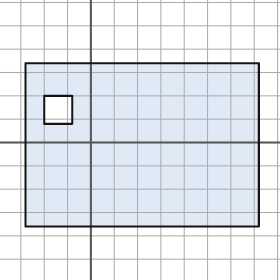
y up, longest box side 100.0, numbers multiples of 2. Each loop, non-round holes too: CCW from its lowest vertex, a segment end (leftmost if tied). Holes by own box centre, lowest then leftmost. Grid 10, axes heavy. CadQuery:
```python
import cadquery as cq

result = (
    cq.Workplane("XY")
    .moveTo(-28.0, -36.0)
    .lineTo(72.0, -36.0)
    .lineTo(72.0, 34.0)
    .lineTo(-28.0, 34.0)
    .close()
    .moveTo(-20.0, 8.0)
    .lineTo(-8.0, 8.0)
    .lineTo(-8.0, 20.0)
    .lineTo(-20.0, 20.0)
    .close()
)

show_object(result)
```